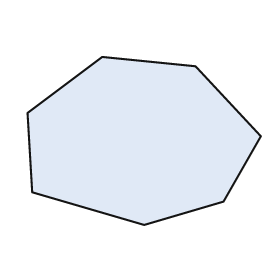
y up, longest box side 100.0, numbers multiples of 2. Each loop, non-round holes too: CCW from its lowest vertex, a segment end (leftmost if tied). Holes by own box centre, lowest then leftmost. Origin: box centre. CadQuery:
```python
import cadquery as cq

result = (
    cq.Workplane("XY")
    .moveTo(0.0, -36.0)
    .lineTo(34.0, -26.0)
    .lineTo(50.0, 2.0)
    .lineTo(22.0, 32.0)
    .lineTo(-18.0, 36.0)
    .lineTo(-50.0, 12.0)
    .lineTo(-48.0, -22.0)
    .close()
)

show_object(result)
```